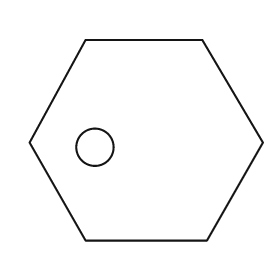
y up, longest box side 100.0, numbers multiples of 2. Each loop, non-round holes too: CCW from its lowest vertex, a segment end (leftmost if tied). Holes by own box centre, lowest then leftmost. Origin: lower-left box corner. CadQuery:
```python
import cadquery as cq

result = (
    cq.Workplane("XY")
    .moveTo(24.0, 0.0)
    .lineTo(76.0, 0.0)
    .lineTo(100.0, 42.0)
    .lineTo(74.0, 86.0)
    .lineTo(24.0, 86.0)
    .lineTo(0.0, 42.0)
    .close()
    .moveTo(28.0, 40.0)
    .circle(8.0)
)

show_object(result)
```